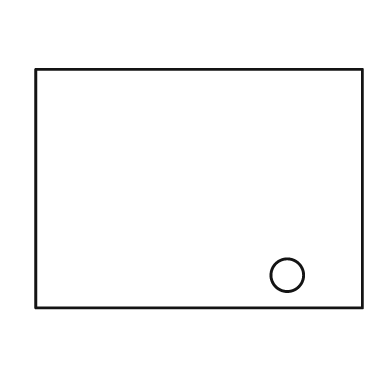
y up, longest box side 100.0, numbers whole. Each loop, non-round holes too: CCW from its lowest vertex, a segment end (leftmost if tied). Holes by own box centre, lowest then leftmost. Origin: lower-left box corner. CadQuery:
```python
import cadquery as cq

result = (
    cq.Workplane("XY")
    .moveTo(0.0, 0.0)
    .lineTo(100.0, 0.0)
    .lineTo(100.0, 73.0)
    .lineTo(0.0, 73.0)
    .close()
    .moveTo(77.0, 10.0)
    .circle(5.0)
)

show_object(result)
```